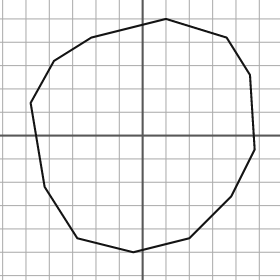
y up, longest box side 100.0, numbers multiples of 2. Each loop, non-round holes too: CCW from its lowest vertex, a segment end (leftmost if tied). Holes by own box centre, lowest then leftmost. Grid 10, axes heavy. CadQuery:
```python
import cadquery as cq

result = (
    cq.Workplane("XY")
    .moveTo(-4.0, -50.0)
    .lineTo(20.0, -44.0)
    .lineTo(38.0, -26.0)
    .lineTo(48.0, -6.0)
    .lineTo(46.0, 26.0)
    .lineTo(36.0, 42.0)
    .lineTo(10.0, 50.0)
    .lineTo(-22.0, 42.0)
    .lineTo(-38.0, 32.0)
    .lineTo(-48.0, 14.0)
    .lineTo(-42.0, -22.0)
    .lineTo(-28.0, -44.0)
    .close()
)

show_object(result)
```